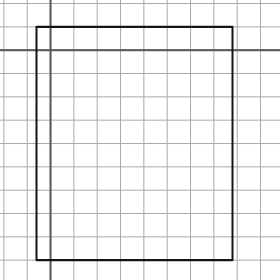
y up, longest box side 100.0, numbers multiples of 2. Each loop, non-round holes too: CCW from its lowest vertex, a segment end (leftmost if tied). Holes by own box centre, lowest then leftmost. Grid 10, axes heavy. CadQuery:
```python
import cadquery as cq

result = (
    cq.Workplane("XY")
    .moveTo(-6.0, -90.0)
    .lineTo(78.0, -90.0)
    .lineTo(78.0, 10.0)
    .lineTo(-6.0, 10.0)
    .close()
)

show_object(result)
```